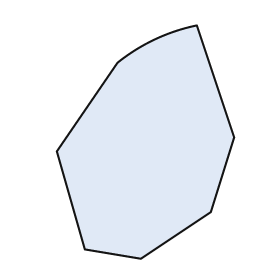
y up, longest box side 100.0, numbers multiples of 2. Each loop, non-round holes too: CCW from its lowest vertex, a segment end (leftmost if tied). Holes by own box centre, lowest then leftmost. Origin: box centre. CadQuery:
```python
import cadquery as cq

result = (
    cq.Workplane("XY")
    .moveTo(-2.0, -50.0)
    .lineTo(28.0, -30.0)
    .lineTo(38.0, 2.0)
    .lineTo(22.0, 50.0)
    .threePointArc((4.0, 44.0), (-12.0, 34.0))
    .lineTo(-38.0, -4.0)
    .lineTo(-26.0, -46.0)
    .close()
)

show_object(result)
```